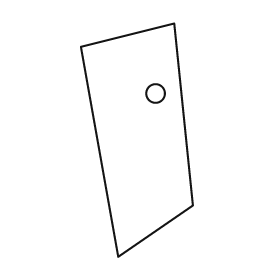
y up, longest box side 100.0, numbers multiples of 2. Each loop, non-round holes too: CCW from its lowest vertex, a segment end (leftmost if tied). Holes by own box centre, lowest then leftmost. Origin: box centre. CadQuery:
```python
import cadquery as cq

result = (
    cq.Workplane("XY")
    .moveTo(-8.0, -50.0)
    .lineTo(24.0, -28.0)
    .lineTo(16.0, 50.0)
    .lineTo(-24.0, 40.0)
    .close()
    .moveTo(8.0, 20.0)
    .circle(4.0)
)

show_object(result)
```